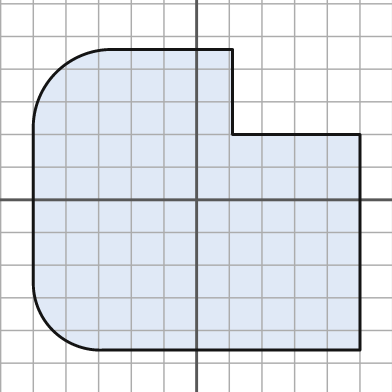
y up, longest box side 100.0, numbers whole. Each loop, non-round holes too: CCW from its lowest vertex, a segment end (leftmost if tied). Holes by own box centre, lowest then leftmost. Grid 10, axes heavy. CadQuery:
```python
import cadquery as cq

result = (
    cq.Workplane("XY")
    .moveTo(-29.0, -46.0)
    .lineTo(50.0, -46.0)
    .lineTo(50.0, 20.0)
    .lineTo(11.0, 20.0)
    .lineTo(11.0, 46.0)
    .lineTo(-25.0, 46.0)
    .threePointArc((-43.0, 39.0), (-50.0, 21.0))
    .lineTo(-50.0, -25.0)
    .threePointArc((-44.0, -40.0), (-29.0, -46.0))
    .close()
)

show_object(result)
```